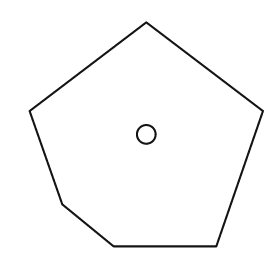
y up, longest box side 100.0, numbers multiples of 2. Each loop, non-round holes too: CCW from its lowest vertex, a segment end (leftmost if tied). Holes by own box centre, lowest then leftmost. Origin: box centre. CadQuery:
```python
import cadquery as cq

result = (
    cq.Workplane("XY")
    .moveTo(-14.0, -48.0)
    .lineTo(30.0, -48.0)
    .lineTo(50.0, 10.0)
    .lineTo(0.0, 48.0)
    .lineTo(-50.0, 10.0)
    .lineTo(-36.0, -30.0)
    .close()
    .moveTo(0.0, 0.0)
    .circle(4.0)
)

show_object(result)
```